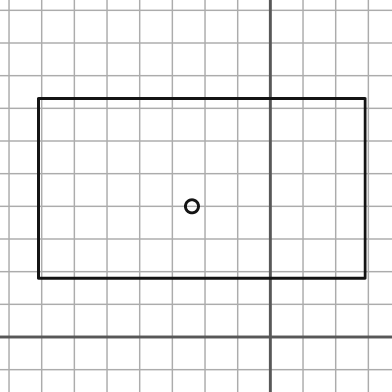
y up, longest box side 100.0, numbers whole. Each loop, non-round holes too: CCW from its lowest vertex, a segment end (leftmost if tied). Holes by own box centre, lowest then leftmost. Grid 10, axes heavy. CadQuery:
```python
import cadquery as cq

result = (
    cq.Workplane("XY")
    .moveTo(-71.0, 18.0)
    .lineTo(29.0, 18.0)
    .lineTo(29.0, 73.0)
    .lineTo(-71.0, 73.0)
    .close()
    .moveTo(-24.0, 40.0)
    .circle(2.0)
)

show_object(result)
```